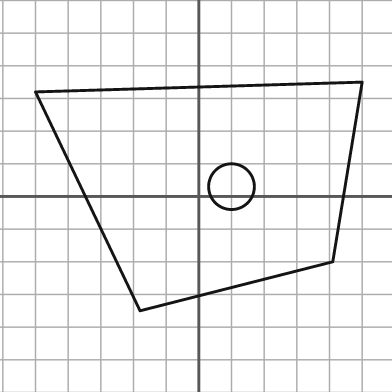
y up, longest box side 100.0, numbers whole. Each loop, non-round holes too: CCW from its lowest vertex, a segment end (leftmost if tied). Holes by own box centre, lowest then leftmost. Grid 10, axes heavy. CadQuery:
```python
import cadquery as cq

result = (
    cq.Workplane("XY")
    .moveTo(-18.0, -35.0)
    .lineTo(41.0, -20.0)
    .lineTo(50.0, 35.0)
    .lineTo(-50.0, 32.0)
    .close()
    .moveTo(10.0, 3.0)
    .circle(7.0)
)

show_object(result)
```